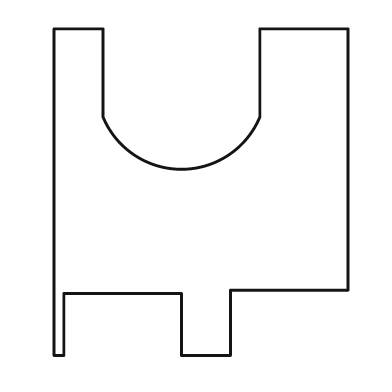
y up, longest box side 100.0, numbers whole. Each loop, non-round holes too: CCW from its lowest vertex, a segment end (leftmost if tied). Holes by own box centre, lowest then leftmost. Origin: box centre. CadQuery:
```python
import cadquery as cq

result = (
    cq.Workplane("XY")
    .moveTo(-45.0, -50.0)
    .lineTo(-42.0, -50.0)
    .lineTo(-42.0, -31.0)
    .lineTo(-6.0, -31.0)
    .lineTo(-6.0, -50.0)
    .lineTo(9.0, -50.0)
    .lineTo(9.0, -30.0)
    .lineTo(45.0, -30.0)
    .lineTo(45.0, 50.0)
    .lineTo(18.0, 50.0)
    .lineTo(18.0, 23.0)
    .threePointArc((-6.0, 7.0), (-30.0, 23.0))
    .lineTo(-30.0, 50.0)
    .lineTo(-45.0, 50.0)
    .close()
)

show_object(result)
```